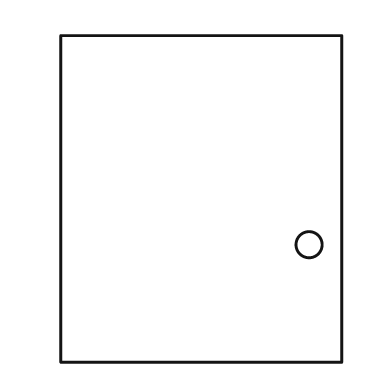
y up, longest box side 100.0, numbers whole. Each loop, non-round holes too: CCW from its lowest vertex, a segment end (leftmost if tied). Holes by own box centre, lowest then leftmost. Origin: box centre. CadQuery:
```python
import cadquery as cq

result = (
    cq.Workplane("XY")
    .moveTo(-43.0, -50.0)
    .lineTo(43.0, -50.0)
    .lineTo(43.0, 50.0)
    .lineTo(-43.0, 50.0)
    .close()
    .moveTo(33.0, -14.0)
    .circle(4.0)
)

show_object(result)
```